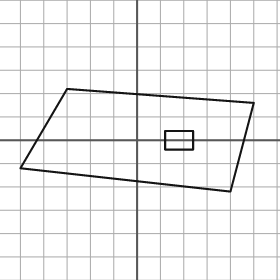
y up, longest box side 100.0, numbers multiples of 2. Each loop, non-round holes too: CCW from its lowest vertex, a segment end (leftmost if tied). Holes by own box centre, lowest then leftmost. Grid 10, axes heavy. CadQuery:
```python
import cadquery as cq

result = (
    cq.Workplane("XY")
    .moveTo(40.0, -22.0)
    .lineTo(50.0, 16.0)
    .lineTo(-30.0, 22.0)
    .lineTo(-50.0, -12.0)
    .close()
    .moveTo(12.0, -4.0)
    .lineTo(24.0, -4.0)
    .lineTo(24.0, 4.0)
    .lineTo(12.0, 4.0)
    .close()
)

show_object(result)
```